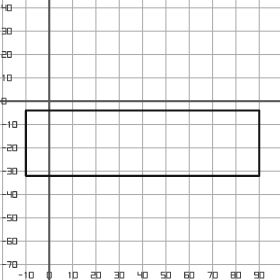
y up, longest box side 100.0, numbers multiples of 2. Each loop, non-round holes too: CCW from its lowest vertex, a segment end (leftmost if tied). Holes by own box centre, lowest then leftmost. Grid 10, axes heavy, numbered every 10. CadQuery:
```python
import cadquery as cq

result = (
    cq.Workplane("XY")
    .moveTo(-10.0, -32.0)
    .lineTo(90.0, -32.0)
    .lineTo(90.0, -4.0)
    .lineTo(-10.0, -4.0)
    .close()
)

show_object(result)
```